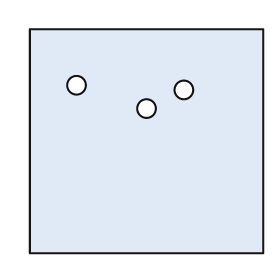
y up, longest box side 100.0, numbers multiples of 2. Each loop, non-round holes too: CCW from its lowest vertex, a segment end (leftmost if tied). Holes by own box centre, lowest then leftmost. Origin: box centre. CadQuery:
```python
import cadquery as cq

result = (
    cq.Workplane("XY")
    .moveTo(-50.0, -48.0)
    .lineTo(50.0, -48.0)
    .lineTo(50.0, 48.0)
    .lineTo(-50.0, 48.0)
    .close()
    .moveTo(0.0, 14.0)
    .circle(4.0)
    .moveTo(16.0, 22.0)
    .circle(4.0)
    .moveTo(-30.0, 24.0)
    .circle(4.0)
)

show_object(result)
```